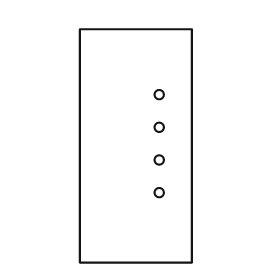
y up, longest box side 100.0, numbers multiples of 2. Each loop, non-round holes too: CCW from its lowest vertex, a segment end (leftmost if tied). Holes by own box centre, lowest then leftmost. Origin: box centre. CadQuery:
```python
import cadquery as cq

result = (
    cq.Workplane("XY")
    .moveTo(-24.0, -50.0)
    .lineTo(24.0, -50.0)
    .lineTo(24.0, 50.0)
    .lineTo(-24.0, 50.0)
    .close()
    .moveTo(10.0, -20.0)
    .circle(2.0)
    .moveTo(10.0, -6.0)
    .circle(2.0)
    .moveTo(10.0, 8.0)
    .circle(2.0)
    .moveTo(10.0, 22.0)
    .circle(2.0)
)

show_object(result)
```